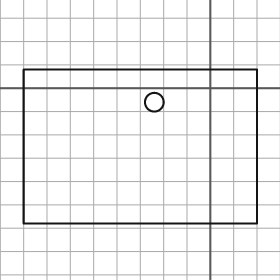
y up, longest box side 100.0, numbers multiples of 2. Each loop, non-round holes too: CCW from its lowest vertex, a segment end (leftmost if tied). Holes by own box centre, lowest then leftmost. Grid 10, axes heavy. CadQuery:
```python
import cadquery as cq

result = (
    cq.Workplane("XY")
    .moveTo(-80.0, -58.0)
    .lineTo(20.0, -58.0)
    .lineTo(20.0, 8.0)
    .lineTo(-80.0, 8.0)
    .close()
    .moveTo(-24.0, -6.0)
    .circle(4.0)
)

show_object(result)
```